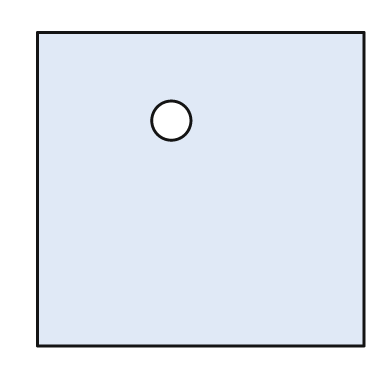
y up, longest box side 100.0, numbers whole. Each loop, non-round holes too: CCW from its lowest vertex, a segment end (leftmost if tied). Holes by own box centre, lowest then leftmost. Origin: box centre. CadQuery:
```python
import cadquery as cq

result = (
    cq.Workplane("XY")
    .moveTo(-50.0, -48.0)
    .lineTo(50.0, -48.0)
    .lineTo(50.0, 48.0)
    .lineTo(-50.0, 48.0)
    .close()
    .moveTo(-9.0, 21.0)
    .circle(6.0)
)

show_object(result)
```